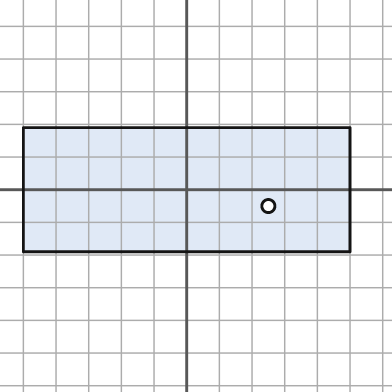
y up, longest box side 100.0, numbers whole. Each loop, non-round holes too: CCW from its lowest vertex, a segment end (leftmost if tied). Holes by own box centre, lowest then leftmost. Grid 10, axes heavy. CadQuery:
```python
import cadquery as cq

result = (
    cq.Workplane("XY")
    .moveTo(-50.0, -19.0)
    .lineTo(50.0, -19.0)
    .lineTo(50.0, 19.0)
    .lineTo(-50.0, 19.0)
    .close()
    .moveTo(25.0, -5.0)
    .circle(2.0)
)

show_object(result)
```